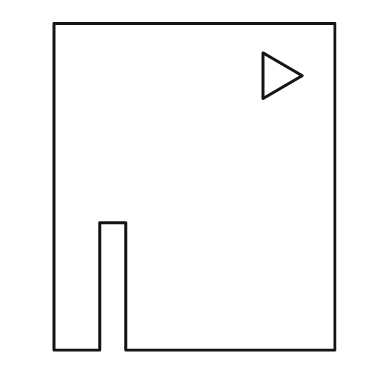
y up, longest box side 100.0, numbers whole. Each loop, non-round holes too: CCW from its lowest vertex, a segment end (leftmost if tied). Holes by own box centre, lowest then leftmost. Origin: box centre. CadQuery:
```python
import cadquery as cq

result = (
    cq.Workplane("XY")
    .moveTo(-43.0, -50.0)
    .lineTo(-29.0, -50.0)
    .lineTo(-29.0, -11.0)
    .lineTo(-21.0, -11.0)
    .lineTo(-21.0, -50.0)
    .lineTo(43.0, -50.0)
    .lineTo(43.0, 50.0)
    .lineTo(-43.0, 50.0)
    .close()
    .moveTo(21.0, 27.0)
    .lineTo(33.0, 34.0)
    .lineTo(21.0, 41.0)
    .close()
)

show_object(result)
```